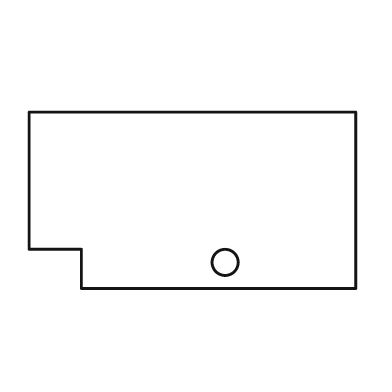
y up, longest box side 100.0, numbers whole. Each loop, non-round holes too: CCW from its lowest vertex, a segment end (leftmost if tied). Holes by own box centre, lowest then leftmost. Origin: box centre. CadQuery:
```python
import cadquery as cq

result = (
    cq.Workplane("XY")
    .moveTo(-34.0, -27.0)
    .lineTo(50.0, -27.0)
    .lineTo(50.0, 27.0)
    .lineTo(-50.0, 27.0)
    .lineTo(-50.0, -15.0)
    .lineTo(-34.0, -15.0)
    .close()
    .moveTo(10.0, -19.0)
    .circle(4.0)
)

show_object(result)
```